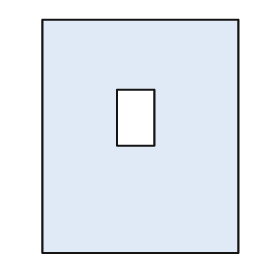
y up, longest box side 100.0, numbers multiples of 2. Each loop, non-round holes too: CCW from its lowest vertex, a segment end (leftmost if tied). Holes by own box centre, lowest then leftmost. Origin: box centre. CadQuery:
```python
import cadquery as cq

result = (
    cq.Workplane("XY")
    .moveTo(-42.0, -50.0)
    .lineTo(42.0, -50.0)
    .lineTo(42.0, 50.0)
    .lineTo(-42.0, 50.0)
    .close()
    .moveTo(-10.0, -4.0)
    .lineTo(6.0, -4.0)
    .lineTo(6.0, 20.0)
    .lineTo(-10.0, 20.0)
    .close()
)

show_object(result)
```